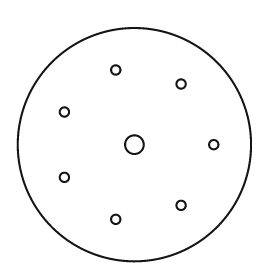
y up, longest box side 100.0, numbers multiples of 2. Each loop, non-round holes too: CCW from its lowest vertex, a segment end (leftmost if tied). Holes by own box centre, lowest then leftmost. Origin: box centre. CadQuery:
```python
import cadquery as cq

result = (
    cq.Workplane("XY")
    .moveTo(0.0, 0.0)
    .circle(50.0)
    .moveTo(-8.0, -32.0)
    .circle(2.0)
    .moveTo(20.0, -26.0)
    .circle(2.0)
    .moveTo(-30.0, -14.0)
    .circle(2.0)
    .moveTo(0.0, 0.0)
    .circle(4.0)
    .moveTo(34.0, 0.0)
    .circle(2.0)
    .moveTo(-30.0, 14.0)
    .circle(2.0)
    .moveTo(20.0, 26.0)
    .circle(2.0)
    .moveTo(-8.0, 32.0)
    .circle(2.0)
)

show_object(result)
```